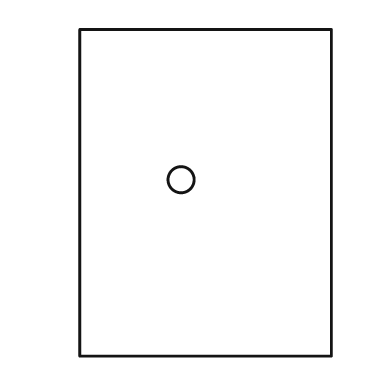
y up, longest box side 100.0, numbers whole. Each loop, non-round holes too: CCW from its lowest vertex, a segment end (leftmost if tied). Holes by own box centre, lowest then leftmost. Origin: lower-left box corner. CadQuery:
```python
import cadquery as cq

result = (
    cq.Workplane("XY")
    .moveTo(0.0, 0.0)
    .lineTo(77.0, 0.0)
    .lineTo(77.0, 100.0)
    .lineTo(0.0, 100.0)
    .close()
    .moveTo(31.0, 54.0)
    .circle(4.0)
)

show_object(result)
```